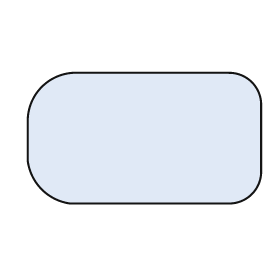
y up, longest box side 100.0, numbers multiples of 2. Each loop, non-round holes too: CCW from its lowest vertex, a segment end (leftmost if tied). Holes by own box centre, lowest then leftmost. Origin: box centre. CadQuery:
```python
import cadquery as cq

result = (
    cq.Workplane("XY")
    .moveTo(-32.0, -28.0)
    .lineTo(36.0, -28.0)
    .threePointArc((46.0, -24.0), (50.0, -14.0))
    .lineTo(50.0, 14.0)
    .threePointArc((46.0, 24.0), (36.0, 28.0))
    .lineTo(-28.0, 28.0)
    .threePointArc((-44.0, 22.0), (-50.0, 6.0))
    .lineTo(-50.0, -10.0)
    .threePointArc((-44.0, -22.0), (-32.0, -28.0))
    .close()
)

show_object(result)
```